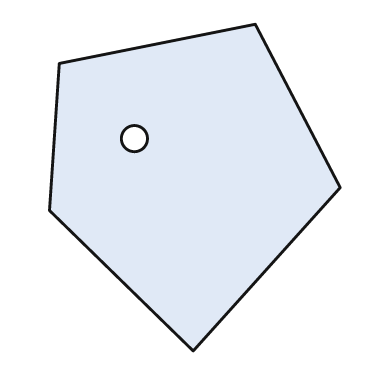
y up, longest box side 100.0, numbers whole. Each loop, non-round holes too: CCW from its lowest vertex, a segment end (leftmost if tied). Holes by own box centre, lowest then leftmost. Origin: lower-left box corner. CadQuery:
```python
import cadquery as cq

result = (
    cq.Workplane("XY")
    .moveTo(44.0, 0.0)
    .lineTo(89.0, 50.0)
    .lineTo(63.0, 100.0)
    .lineTo(3.0, 88.0)
    .lineTo(0.0, 43.0)
    .close()
    .moveTo(26.0, 65.0)
    .circle(4.0)
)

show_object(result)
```